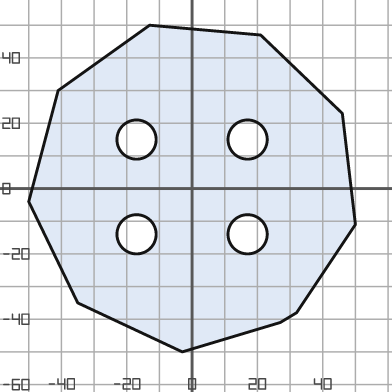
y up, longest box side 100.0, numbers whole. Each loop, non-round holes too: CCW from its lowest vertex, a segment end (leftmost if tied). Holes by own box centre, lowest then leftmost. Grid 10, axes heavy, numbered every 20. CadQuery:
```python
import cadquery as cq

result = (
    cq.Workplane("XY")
    .moveTo(-3.0, -50.0)
    .lineTo(27.0, -41.0)
    .lineTo(32.0, -38.0)
    .lineTo(50.0, -11.0)
    .lineTo(46.0, 23.0)
    .lineTo(21.0, 47.0)
    .lineTo(-13.0, 50.0)
    .lineTo(-41.0, 30.0)
    .lineTo(-50.0, -4.0)
    .lineTo(-35.0, -35.0)
    .close()
    .moveTo(-17.0, -14.0)
    .circle(6.0)
    .moveTo(17.0, -14.0)
    .circle(6.0)
    .moveTo(-17.0, 15.0)
    .circle(6.0)
    .moveTo(17.0, 15.0)
    .circle(6.0)
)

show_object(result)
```